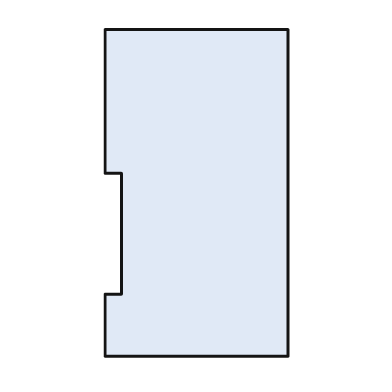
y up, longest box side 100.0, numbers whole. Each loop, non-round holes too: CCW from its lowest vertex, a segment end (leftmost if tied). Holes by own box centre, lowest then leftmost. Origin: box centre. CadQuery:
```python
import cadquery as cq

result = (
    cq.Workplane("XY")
    .moveTo(-28.0, -50.0)
    .lineTo(28.0, -50.0)
    .lineTo(28.0, 50.0)
    .lineTo(-28.0, 50.0)
    .lineTo(-28.0, 6.0)
    .lineTo(-23.0, 6.0)
    .lineTo(-23.0, -31.0)
    .lineTo(-28.0, -31.0)
    .close()
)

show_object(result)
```